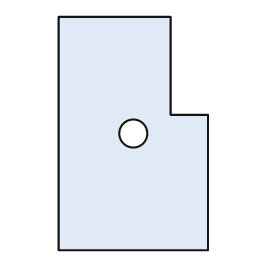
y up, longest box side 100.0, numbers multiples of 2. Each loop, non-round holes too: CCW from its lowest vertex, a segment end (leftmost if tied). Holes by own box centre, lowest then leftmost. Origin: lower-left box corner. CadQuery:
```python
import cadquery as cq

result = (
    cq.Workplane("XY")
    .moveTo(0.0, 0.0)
    .lineTo(64.0, 0.0)
    .lineTo(64.0, 58.0)
    .lineTo(48.0, 58.0)
    .lineTo(48.0, 100.0)
    .lineTo(0.0, 100.0)
    .close()
    .moveTo(32.0, 50.0)
    .circle(6.0)
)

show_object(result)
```